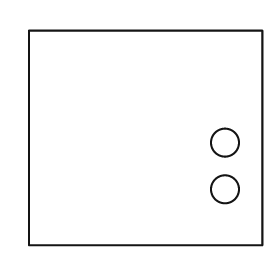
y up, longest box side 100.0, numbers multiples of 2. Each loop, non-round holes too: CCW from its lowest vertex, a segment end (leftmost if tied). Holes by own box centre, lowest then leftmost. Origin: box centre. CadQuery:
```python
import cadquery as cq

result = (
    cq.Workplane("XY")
    .moveTo(-50.0, -46.0)
    .lineTo(50.0, -46.0)
    .lineTo(50.0, 46.0)
    .lineTo(-50.0, 46.0)
    .close()
    .moveTo(34.0, -22.0)
    .circle(6.0)
    .moveTo(34.0, -2.0)
    .circle(6.0)
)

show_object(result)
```